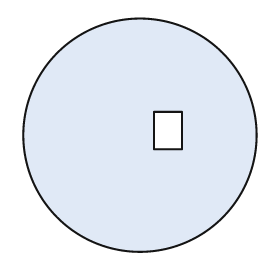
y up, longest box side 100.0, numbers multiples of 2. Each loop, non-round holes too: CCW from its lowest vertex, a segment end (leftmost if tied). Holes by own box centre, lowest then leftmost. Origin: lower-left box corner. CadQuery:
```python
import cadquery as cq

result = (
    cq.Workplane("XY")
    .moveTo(50.0, 50.0)
    .circle(50.0)
    .moveTo(56.0, 44.0)
    .lineTo(68.0, 44.0)
    .lineTo(68.0, 60.0)
    .lineTo(56.0, 60.0)
    .close()
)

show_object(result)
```